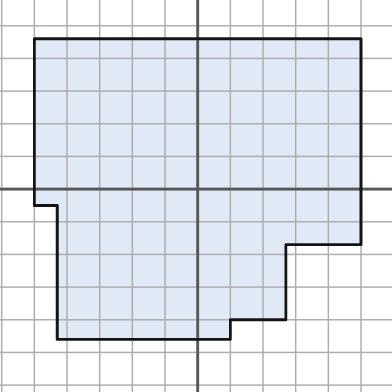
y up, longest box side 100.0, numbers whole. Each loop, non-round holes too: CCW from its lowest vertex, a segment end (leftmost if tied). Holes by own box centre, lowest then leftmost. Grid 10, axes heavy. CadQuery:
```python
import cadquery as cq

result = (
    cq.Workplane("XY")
    .moveTo(-43.0, -46.0)
    .lineTo(10.0, -46.0)
    .lineTo(10.0, -40.0)
    .lineTo(27.0, -40.0)
    .lineTo(27.0, -17.0)
    .lineTo(50.0, -17.0)
    .lineTo(50.0, 46.0)
    .lineTo(-50.0, 46.0)
    .lineTo(-50.0, -5.0)
    .lineTo(-43.0, -5.0)
    .close()
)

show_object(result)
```